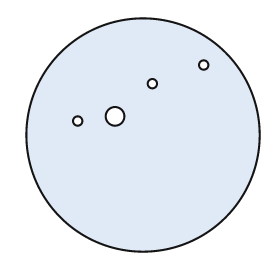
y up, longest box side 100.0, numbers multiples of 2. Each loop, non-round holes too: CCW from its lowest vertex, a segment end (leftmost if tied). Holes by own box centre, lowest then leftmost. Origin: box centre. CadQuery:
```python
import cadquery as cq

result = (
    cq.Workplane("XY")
    .moveTo(0.0, 0.0)
    .circle(50.0)
    .moveTo(-28.0, 6.0)
    .circle(2.0)
    .moveTo(-12.0, 8.0)
    .circle(4.0)
    .moveTo(4.0, 22.0)
    .circle(2.0)
    .moveTo(26.0, 30.0)
    .circle(2.0)
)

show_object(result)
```